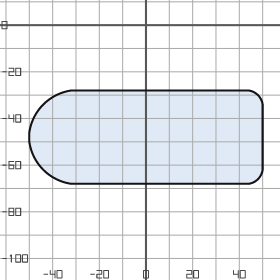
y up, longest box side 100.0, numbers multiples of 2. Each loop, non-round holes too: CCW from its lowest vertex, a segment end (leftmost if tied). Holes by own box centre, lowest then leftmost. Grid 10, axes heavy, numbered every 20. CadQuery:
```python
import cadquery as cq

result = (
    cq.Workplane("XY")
    .moveTo(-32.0, -68.0)
    .lineTo(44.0, -68.0)
    .threePointArc((48.0, -66.0), (50.0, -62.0))
    .lineTo(50.0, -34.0)
    .threePointArc((48.0, -30.0), (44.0, -28.0))
    .lineTo(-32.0, -28.0)
    .threePointArc((-44.0, -34.0), (-50.0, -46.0))
    .lineTo(-50.0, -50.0)
    .threePointArc((-44.0, -62.0), (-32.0, -68.0))
    .close()
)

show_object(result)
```